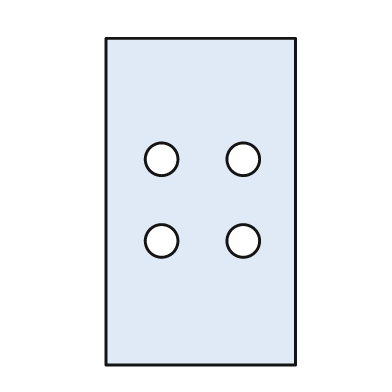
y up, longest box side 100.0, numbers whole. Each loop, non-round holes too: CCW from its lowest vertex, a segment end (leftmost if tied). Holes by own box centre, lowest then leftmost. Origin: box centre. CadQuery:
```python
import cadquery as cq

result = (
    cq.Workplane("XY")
    .moveTo(-29.0, -50.0)
    .lineTo(29.0, -50.0)
    .lineTo(29.0, 50.0)
    .lineTo(-29.0, 50.0)
    .close()
    .moveTo(-12.0, -12.0)
    .circle(5.0)
    .moveTo(13.0, -12.0)
    .circle(5.0)
    .moveTo(-12.0, 13.0)
    .circle(5.0)
    .moveTo(13.0, 13.0)
    .circle(5.0)
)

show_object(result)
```